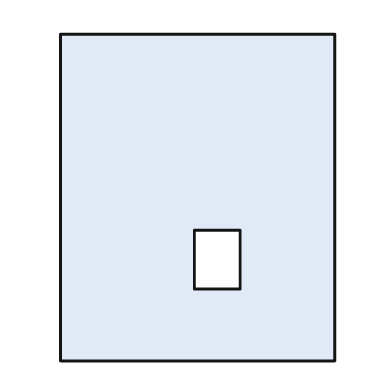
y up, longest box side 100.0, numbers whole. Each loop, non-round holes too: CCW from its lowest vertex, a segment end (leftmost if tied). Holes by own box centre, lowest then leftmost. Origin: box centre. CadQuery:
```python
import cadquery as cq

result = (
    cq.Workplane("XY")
    .moveTo(-42.0, -50.0)
    .lineTo(42.0, -50.0)
    .lineTo(42.0, 50.0)
    .lineTo(-42.0, 50.0)
    .close()
    .moveTo(-1.0, -28.0)
    .lineTo(13.0, -28.0)
    .lineTo(13.0, -10.0)
    .lineTo(-1.0, -10.0)
    .close()
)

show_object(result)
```